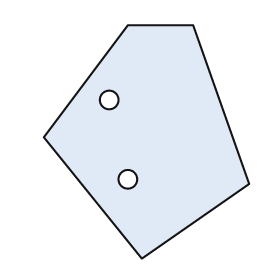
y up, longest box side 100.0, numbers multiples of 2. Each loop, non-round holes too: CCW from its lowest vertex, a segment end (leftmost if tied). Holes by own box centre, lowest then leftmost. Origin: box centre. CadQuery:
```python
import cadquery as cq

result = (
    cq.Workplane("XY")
    .moveTo(-2.0, -50.0)
    .lineTo(44.0, -18.0)
    .lineTo(20.0, 50.0)
    .lineTo(-8.0, 50.0)
    .lineTo(-44.0, 2.0)
    .close()
    .moveTo(-8.0, -16.0)
    .circle(4.0)
    .moveTo(-16.0, 18.0)
    .circle(4.0)
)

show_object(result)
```